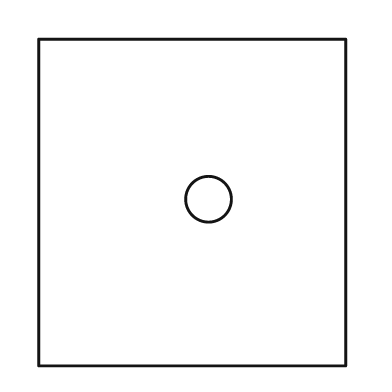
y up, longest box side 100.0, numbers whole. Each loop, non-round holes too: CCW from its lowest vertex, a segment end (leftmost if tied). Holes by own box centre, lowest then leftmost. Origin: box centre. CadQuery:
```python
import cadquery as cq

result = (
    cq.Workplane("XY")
    .moveTo(-47.0, -50.0)
    .lineTo(47.0, -50.0)
    .lineTo(47.0, 50.0)
    .lineTo(-47.0, 50.0)
    .close()
    .moveTo(5.0, 1.0)
    .circle(7.0)
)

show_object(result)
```